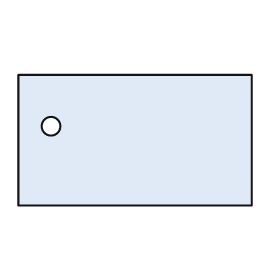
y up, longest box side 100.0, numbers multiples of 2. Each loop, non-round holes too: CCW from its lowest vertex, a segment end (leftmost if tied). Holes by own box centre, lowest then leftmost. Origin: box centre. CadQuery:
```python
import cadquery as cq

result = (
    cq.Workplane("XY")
    .moveTo(-50.0, -28.0)
    .lineTo(50.0, -28.0)
    .lineTo(50.0, 28.0)
    .lineTo(-50.0, 28.0)
    .close()
    .moveTo(-36.0, 6.0)
    .circle(4.0)
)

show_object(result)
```